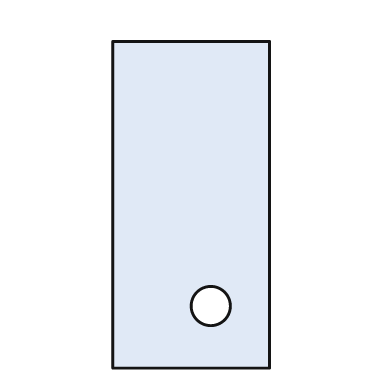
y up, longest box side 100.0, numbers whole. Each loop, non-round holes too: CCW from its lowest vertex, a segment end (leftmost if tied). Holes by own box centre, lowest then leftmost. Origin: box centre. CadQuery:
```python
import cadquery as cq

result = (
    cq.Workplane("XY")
    .moveTo(-24.0, -50.0)
    .lineTo(24.0, -50.0)
    .lineTo(24.0, 50.0)
    .lineTo(-24.0, 50.0)
    .close()
    .moveTo(6.0, -31.0)
    .circle(6.0)
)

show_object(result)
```